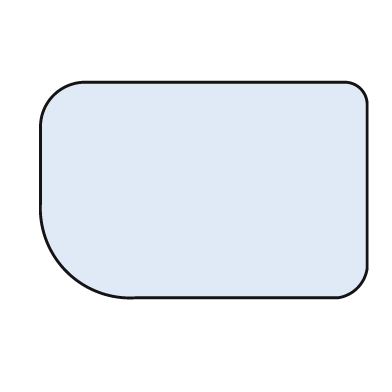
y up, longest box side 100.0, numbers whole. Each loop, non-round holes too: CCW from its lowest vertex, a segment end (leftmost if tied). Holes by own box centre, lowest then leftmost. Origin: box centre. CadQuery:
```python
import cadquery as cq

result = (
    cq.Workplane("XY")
    .moveTo(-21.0, -33.0)
    .lineTo(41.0, -33.0)
    .threePointArc((47.0, -30.0), (50.0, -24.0))
    .lineTo(50.0, 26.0)
    .threePointArc((48.0, 31.0), (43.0, 33.0))
    .lineTo(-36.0, 33.0)
    .threePointArc((-46.0, 29.0), (-50.0, 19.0))
    .lineTo(-50.0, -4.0)
    .threePointArc((-42.0, -25.0), (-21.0, -33.0))
    .close()
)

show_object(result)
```